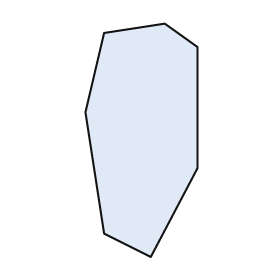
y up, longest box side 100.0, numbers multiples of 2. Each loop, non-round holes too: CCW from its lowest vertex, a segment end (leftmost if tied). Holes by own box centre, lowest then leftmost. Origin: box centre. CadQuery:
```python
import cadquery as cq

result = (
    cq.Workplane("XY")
    .moveTo(4.0, -50.0)
    .lineTo(24.0, -12.0)
    .lineTo(24.0, 40.0)
    .lineTo(10.0, 50.0)
    .lineTo(-16.0, 46.0)
    .lineTo(-24.0, 12.0)
    .lineTo(-16.0, -40.0)
    .close()
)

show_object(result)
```